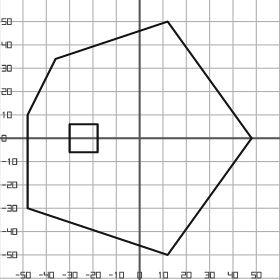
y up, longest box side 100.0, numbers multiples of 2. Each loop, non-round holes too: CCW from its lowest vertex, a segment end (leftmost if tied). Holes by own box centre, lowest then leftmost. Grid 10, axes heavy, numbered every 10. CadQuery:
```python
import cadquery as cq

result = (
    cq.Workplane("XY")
    .moveTo(12.0, -50.0)
    .lineTo(48.0, 0.0)
    .lineTo(12.0, 50.0)
    .lineTo(-36.0, 34.0)
    .lineTo(-48.0, 10.0)
    .lineTo(-48.0, -30.0)
    .close()
    .moveTo(-30.0, -6.0)
    .lineTo(-18.0, -6.0)
    .lineTo(-18.0, 6.0)
    .lineTo(-30.0, 6.0)
    .close()
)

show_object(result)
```